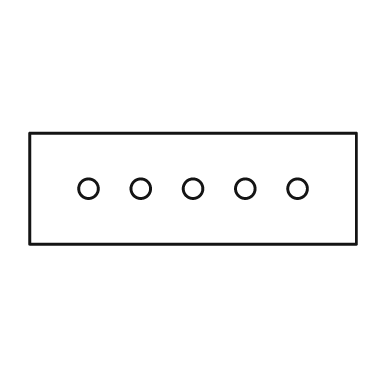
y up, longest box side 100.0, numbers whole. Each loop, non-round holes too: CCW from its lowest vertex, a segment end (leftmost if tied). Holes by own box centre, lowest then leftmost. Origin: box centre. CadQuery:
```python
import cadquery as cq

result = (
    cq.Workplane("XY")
    .moveTo(-50.0, -17.0)
    .lineTo(50.0, -17.0)
    .lineTo(50.0, 17.0)
    .lineTo(-50.0, 17.0)
    .close()
    .moveTo(-32.0, 0.0)
    .circle(3.0)
    .moveTo(-16.0, 0.0)
    .circle(3.0)
    .moveTo(0.0, 0.0)
    .circle(3.0)
    .moveTo(16.0, 0.0)
    .circle(3.0)
    .moveTo(32.0, 0.0)
    .circle(3.0)
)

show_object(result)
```